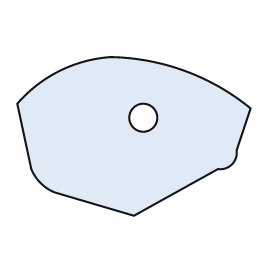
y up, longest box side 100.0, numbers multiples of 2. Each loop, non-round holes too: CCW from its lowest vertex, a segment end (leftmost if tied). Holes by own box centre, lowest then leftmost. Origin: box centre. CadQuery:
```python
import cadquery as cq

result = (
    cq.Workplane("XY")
    .moveTo(0.0, -34.0)
    .lineTo(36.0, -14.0)
    .threePointArc((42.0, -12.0), (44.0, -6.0))
    .lineTo(50.0, 12.0)
    .threePointArc((22.0, 28.0), (-10.0, 34.0))
    .threePointArc((-32.0, 28.0), (-50.0, 14.0))
    .lineTo(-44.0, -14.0)
    .threePointArc((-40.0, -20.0), (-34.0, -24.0))
    .close()
    .moveTo(4.0, 8.0)
    .circle(6.0)
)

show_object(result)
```